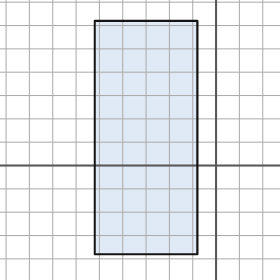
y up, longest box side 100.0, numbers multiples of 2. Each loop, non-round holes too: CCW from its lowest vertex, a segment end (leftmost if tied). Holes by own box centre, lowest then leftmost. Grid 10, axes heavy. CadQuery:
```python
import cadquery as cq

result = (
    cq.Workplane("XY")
    .moveTo(-52.0, -38.0)
    .lineTo(-8.0, -38.0)
    .lineTo(-8.0, 62.0)
    .lineTo(-52.0, 62.0)
    .close()
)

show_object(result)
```